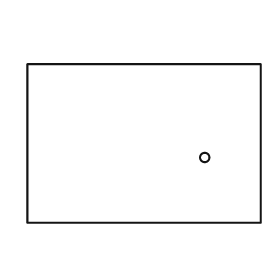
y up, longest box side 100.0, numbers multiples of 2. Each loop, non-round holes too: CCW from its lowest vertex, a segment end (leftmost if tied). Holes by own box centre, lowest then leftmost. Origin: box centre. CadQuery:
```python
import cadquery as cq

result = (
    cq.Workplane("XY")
    .moveTo(-50.0, -34.0)
    .lineTo(50.0, -34.0)
    .lineTo(50.0, 34.0)
    .lineTo(-50.0, 34.0)
    .close()
    .moveTo(26.0, -6.0)
    .circle(2.0)
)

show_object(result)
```